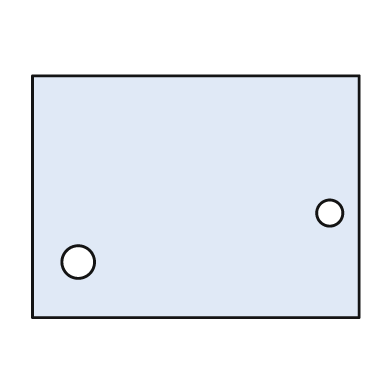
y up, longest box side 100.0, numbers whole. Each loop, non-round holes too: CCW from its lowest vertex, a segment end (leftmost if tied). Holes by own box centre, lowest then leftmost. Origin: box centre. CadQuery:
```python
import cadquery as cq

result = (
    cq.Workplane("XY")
    .moveTo(-50.0, -37.0)
    .lineTo(50.0, -37.0)
    .lineTo(50.0, 37.0)
    .lineTo(-50.0, 37.0)
    .close()
    .moveTo(-36.0, -20.0)
    .circle(5.0)
    .moveTo(41.0, -5.0)
    .circle(4.0)
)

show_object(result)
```